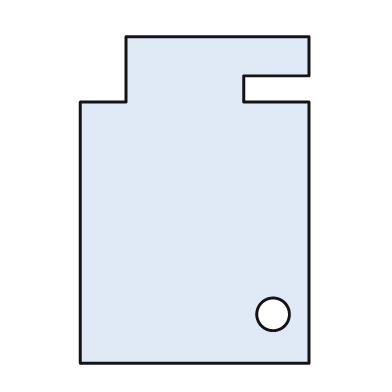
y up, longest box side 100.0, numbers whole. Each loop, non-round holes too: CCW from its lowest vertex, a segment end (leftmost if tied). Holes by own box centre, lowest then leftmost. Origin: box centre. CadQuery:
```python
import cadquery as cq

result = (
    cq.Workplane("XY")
    .moveTo(-35.0, -50.0)
    .lineTo(35.0, -50.0)
    .lineTo(35.0, 30.0)
    .lineTo(15.0, 30.0)
    .lineTo(15.0, 38.0)
    .lineTo(35.0, 38.0)
    .lineTo(35.0, 50.0)
    .lineTo(-21.0, 50.0)
    .lineTo(-21.0, 30.0)
    .lineTo(-35.0, 30.0)
    .close()
    .moveTo(24.0, -35.0)
    .circle(5.0)
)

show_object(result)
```